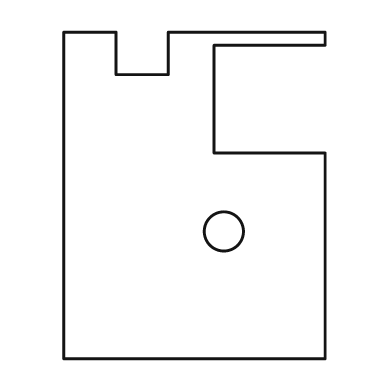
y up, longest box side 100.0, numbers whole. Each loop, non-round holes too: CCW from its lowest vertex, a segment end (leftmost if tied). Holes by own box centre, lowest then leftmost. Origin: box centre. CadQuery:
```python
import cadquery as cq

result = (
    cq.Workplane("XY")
    .moveTo(-40.0, -50.0)
    .lineTo(40.0, -50.0)
    .lineTo(40.0, 13.0)
    .lineTo(6.0, 13.0)
    .lineTo(6.0, 46.0)
    .lineTo(40.0, 46.0)
    .lineTo(40.0, 50.0)
    .lineTo(-8.0, 50.0)
    .lineTo(-8.0, 37.0)
    .lineTo(-24.0, 37.0)
    .lineTo(-24.0, 50.0)
    .lineTo(-40.0, 50.0)
    .close()
    .moveTo(9.0, -11.0)
    .circle(6.0)
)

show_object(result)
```